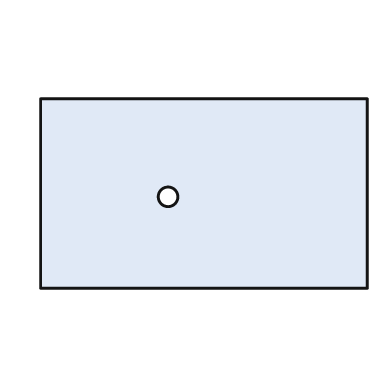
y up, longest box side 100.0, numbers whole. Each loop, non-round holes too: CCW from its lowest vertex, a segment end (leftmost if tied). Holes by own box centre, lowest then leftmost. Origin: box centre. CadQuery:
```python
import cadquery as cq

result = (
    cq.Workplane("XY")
    .moveTo(-50.0, -29.0)
    .lineTo(50.0, -29.0)
    .lineTo(50.0, 29.0)
    .lineTo(-50.0, 29.0)
    .close()
    .moveTo(-11.0, -1.0)
    .circle(3.0)
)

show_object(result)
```